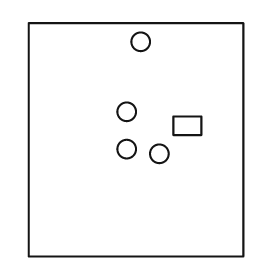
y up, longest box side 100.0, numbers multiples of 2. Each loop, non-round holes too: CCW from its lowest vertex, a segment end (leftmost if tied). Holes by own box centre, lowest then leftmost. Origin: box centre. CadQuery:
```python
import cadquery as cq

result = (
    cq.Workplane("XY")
    .moveTo(-46.0, -50.0)
    .lineTo(46.0, -50.0)
    .lineTo(46.0, 50.0)
    .lineTo(-46.0, 50.0)
    .close()
    .moveTo(10.0, -6.0)
    .circle(4.0)
    .moveTo(-4.0, -4.0)
    .circle(4.0)
    .moveTo(16.0, 2.0)
    .lineTo(28.0, 2.0)
    .lineTo(28.0, 10.0)
    .lineTo(16.0, 10.0)
    .close()
    .moveTo(-4.0, 12.0)
    .circle(4.0)
    .moveTo(2.0, 42.0)
    .circle(4.0)
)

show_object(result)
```